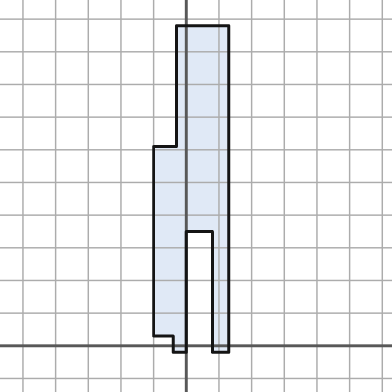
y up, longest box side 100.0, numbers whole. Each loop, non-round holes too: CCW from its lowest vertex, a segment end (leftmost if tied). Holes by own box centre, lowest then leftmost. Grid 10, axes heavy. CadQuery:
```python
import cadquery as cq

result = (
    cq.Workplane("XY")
    .moveTo(-4.0, -2.0)
    .lineTo(0.0, -2.0)
    .lineTo(0.0, 35.0)
    .lineTo(8.0, 35.0)
    .lineTo(8.0, -2.0)
    .lineTo(13.0, -2.0)
    .lineTo(13.0, 98.0)
    .lineTo(-3.0, 98.0)
    .lineTo(-3.0, 61.0)
    .lineTo(-10.0, 61.0)
    .lineTo(-10.0, 3.0)
    .lineTo(-4.0, 3.0)
    .close()
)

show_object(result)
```